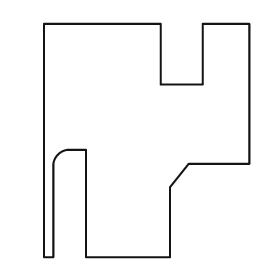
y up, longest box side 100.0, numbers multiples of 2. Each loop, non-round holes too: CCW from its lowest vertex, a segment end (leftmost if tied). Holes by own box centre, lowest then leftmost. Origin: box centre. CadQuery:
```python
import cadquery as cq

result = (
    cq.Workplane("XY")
    .moveTo(-44.0, -50.0)
    .lineTo(-40.0, -50.0)
    .lineTo(-40.0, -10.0)
    .threePointArc((-38.0, -6.0), (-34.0, -4.0))
    .lineTo(-26.0, -4.0)
    .lineTo(-26.0, -50.0)
    .lineTo(10.0, -50.0)
    .lineTo(10.0, -20.0)
    .lineTo(18.0, -10.0)
    .lineTo(44.0, -10.0)
    .lineTo(44.0, 50.0)
    .lineTo(24.0, 50.0)
    .lineTo(24.0, 24.0)
    .lineTo(6.0, 24.0)
    .lineTo(6.0, 50.0)
    .lineTo(-44.0, 50.0)
    .close()
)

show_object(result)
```